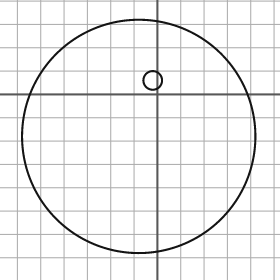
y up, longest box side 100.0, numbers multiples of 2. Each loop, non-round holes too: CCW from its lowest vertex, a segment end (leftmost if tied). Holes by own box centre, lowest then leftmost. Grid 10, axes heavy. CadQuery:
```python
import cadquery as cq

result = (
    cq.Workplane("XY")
    .moveTo(-8.0, -18.0)
    .circle(50.0)
    .moveTo(-2.0, 6.0)
    .circle(4.0)
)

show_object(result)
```